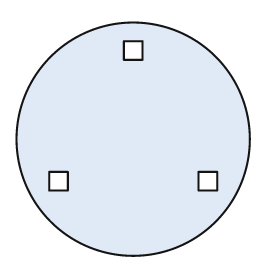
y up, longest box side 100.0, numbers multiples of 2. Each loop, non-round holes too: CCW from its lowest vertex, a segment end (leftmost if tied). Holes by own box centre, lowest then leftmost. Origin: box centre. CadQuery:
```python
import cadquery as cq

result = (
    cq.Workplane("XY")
    .moveTo(0.0, 0.0)
    .circle(50.0)
    .moveTo(-36.0, -22.0)
    .lineTo(-28.0, -22.0)
    .lineTo(-28.0, -14.0)
    .lineTo(-36.0, -14.0)
    .close()
    .moveTo(28.0, -22.0)
    .lineTo(36.0, -22.0)
    .lineTo(36.0, -14.0)
    .lineTo(28.0, -14.0)
    .close()
    .moveTo(-4.0, 34.0)
    .lineTo(4.0, 34.0)
    .lineTo(4.0, 42.0)
    .lineTo(-4.0, 42.0)
    .close()
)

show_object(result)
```